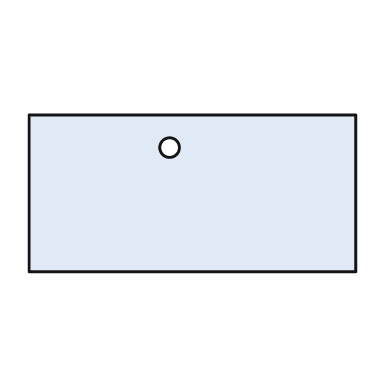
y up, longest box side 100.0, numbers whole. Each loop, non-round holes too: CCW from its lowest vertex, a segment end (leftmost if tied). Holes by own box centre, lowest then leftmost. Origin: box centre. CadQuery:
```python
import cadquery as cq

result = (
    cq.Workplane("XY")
    .moveTo(-50.0, -24.0)
    .lineTo(50.0, -24.0)
    .lineTo(50.0, 24.0)
    .lineTo(-50.0, 24.0)
    .close()
    .moveTo(-7.0, 14.0)
    .circle(3.0)
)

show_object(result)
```